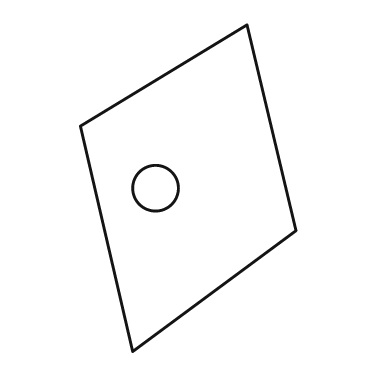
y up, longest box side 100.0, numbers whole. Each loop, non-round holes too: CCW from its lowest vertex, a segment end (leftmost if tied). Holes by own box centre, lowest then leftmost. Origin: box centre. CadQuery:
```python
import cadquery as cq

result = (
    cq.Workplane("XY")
    .moveTo(-17.0, -50.0)
    .lineTo(33.0, -13.0)
    .lineTo(18.0, 50.0)
    .lineTo(-33.0, 19.0)
    .close()
    .moveTo(-10.0, 0.0)
    .circle(7.0)
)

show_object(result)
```